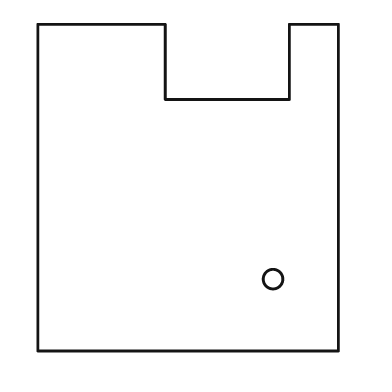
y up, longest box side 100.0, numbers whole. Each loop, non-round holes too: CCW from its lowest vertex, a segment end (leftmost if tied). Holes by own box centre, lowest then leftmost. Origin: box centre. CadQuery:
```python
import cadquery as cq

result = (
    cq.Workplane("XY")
    .moveTo(-46.0, -50.0)
    .lineTo(46.0, -50.0)
    .lineTo(46.0, 50.0)
    .lineTo(31.0, 50.0)
    .lineTo(31.0, 27.0)
    .lineTo(-7.0, 27.0)
    .lineTo(-7.0, 50.0)
    .lineTo(-46.0, 50.0)
    .close()
    .moveTo(26.0, -28.0)
    .circle(3.0)
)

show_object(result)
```